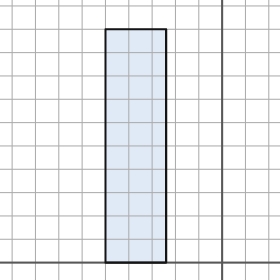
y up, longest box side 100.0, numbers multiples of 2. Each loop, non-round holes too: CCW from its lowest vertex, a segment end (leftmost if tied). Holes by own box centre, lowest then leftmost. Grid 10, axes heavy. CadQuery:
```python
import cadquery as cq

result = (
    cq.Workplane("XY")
    .moveTo(-50.0, 0.0)
    .lineTo(-24.0, 0.0)
    .lineTo(-24.0, 100.0)
    .lineTo(-50.0, 100.0)
    .close()
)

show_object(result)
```